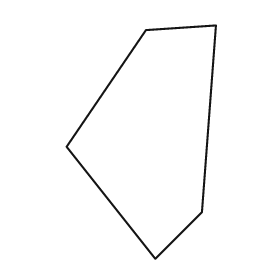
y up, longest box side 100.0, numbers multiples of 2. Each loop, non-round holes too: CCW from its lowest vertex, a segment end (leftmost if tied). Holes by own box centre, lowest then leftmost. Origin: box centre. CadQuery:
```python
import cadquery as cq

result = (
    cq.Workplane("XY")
    .moveTo(6.0, -50.0)
    .lineTo(26.0, -30.0)
    .lineTo(32.0, 50.0)
    .lineTo(2.0, 48.0)
    .lineTo(-32.0, -2.0)
    .close()
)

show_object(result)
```